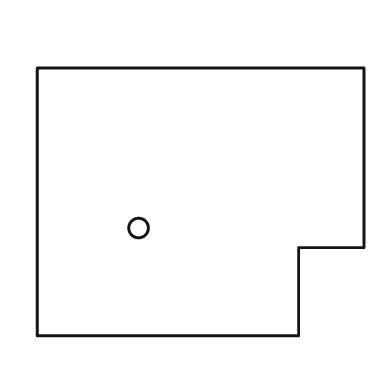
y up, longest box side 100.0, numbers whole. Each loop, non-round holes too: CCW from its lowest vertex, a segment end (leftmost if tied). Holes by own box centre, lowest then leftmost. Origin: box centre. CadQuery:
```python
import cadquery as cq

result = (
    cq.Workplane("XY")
    .moveTo(-50.0, -41.0)
    .lineTo(30.0, -41.0)
    .lineTo(30.0, -14.0)
    .lineTo(50.0, -14.0)
    .lineTo(50.0, 41.0)
    .lineTo(-50.0, 41.0)
    .close()
    .moveTo(-19.0, -8.0)
    .circle(3.0)
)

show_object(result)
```